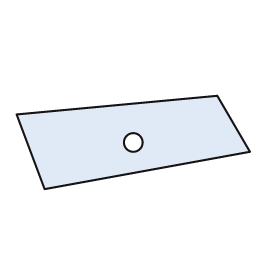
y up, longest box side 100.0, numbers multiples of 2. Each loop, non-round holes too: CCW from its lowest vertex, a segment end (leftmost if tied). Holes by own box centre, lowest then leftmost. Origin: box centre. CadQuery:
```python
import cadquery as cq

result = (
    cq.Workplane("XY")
    .moveTo(-38.0, -20.0)
    .lineTo(50.0, -4.0)
    .lineTo(36.0, 20.0)
    .lineTo(-50.0, 12.0)
    .close()
    .moveTo(0.0, 0.0)
    .circle(4.0)
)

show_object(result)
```